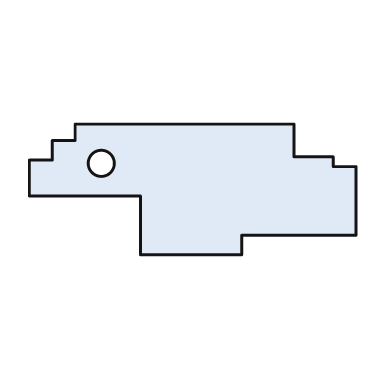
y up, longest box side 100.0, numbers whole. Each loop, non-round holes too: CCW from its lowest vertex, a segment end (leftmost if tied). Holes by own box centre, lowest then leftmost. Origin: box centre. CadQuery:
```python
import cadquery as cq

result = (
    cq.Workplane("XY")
    .moveTo(-16.0, -20.0)
    .lineTo(15.0, -20.0)
    .lineTo(15.0, -14.0)
    .lineTo(50.0, -14.0)
    .lineTo(50.0, 7.0)
    .lineTo(43.0, 7.0)
    .lineTo(43.0, 10.0)
    .lineTo(31.0, 10.0)
    .lineTo(31.0, 20.0)
    .lineTo(-36.0, 20.0)
    .lineTo(-36.0, 15.0)
    .lineTo(-43.0, 15.0)
    .lineTo(-43.0, 9.0)
    .lineTo(-50.0, 9.0)
    .lineTo(-50.0, -2.0)
    .lineTo(-16.0, -2.0)
    .close()
    .moveTo(-28.0, 8.0)
    .circle(4.0)
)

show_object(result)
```